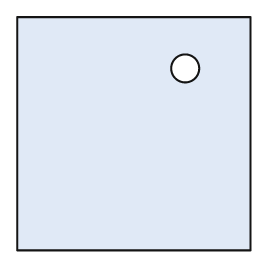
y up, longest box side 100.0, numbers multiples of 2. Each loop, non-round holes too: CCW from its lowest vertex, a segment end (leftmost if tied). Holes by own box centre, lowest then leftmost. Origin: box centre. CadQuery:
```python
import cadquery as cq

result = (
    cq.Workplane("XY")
    .moveTo(-50.0, -50.0)
    .lineTo(50.0, -50.0)
    .lineTo(50.0, 50.0)
    .lineTo(-50.0, 50.0)
    .close()
    .moveTo(22.0, 28.0)
    .circle(6.0)
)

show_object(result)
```